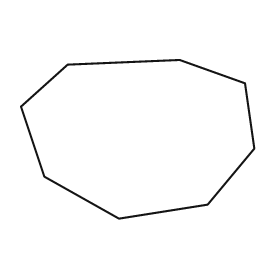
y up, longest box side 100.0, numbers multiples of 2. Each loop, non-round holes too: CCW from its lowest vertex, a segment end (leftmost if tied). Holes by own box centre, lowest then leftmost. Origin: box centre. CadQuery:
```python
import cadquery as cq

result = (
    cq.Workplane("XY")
    .moveTo(-8.0, -34.0)
    .lineTo(30.0, -28.0)
    .lineTo(50.0, -4.0)
    .lineTo(46.0, 24.0)
    .lineTo(18.0, 34.0)
    .lineTo(-30.0, 32.0)
    .lineTo(-50.0, 14.0)
    .lineTo(-40.0, -16.0)
    .close()
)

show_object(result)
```